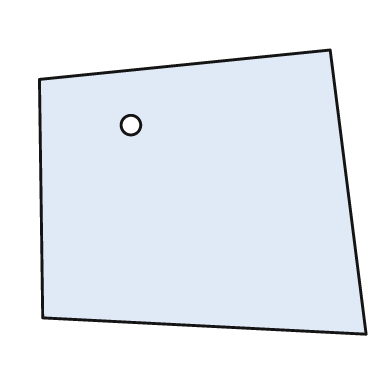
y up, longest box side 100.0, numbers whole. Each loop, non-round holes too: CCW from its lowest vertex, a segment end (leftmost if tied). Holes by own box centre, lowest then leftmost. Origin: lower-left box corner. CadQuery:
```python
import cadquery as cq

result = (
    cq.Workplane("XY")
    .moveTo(100.0, 0.0)
    .lineTo(89.0, 87.0)
    .lineTo(0.0, 78.0)
    .lineTo(1.0, 5.0)
    .close()
    .moveTo(28.0, 64.0)
    .circle(3.0)
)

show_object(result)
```